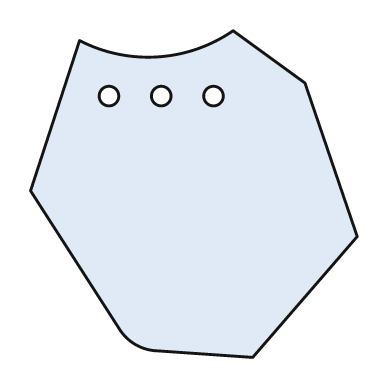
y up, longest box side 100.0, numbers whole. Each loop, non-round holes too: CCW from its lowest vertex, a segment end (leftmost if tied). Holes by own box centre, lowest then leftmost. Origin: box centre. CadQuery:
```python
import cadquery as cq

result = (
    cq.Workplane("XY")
    .moveTo(18.0, -50.0)
    .lineTo(50.0, -13.0)
    .lineTo(34.0, 34.0)
    .lineTo(12.0, 50.0)
    .threePointArc((-11.0, 42.0), (-35.0, 47.0))
    .lineTo(-50.0, 1.0)
    .lineTo(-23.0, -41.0)
    .threePointArc((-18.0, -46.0), (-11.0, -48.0))
    .close()
    .moveTo(-26.0, 30.0)
    .circle(3.0)
    .moveTo(-10.0, 30.0)
    .circle(3.0)
    .moveTo(6.0, 30.0)
    .circle(3.0)
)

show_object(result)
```